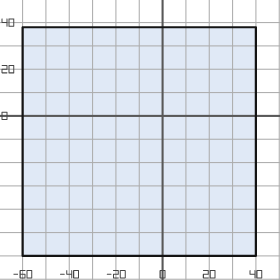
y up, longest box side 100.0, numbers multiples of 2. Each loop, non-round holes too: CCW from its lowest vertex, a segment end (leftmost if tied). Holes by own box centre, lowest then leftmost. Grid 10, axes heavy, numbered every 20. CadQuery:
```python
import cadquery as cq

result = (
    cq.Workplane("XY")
    .moveTo(-60.0, -60.0)
    .lineTo(40.0, -60.0)
    .lineTo(40.0, 38.0)
    .lineTo(-60.0, 38.0)
    .close()
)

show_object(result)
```